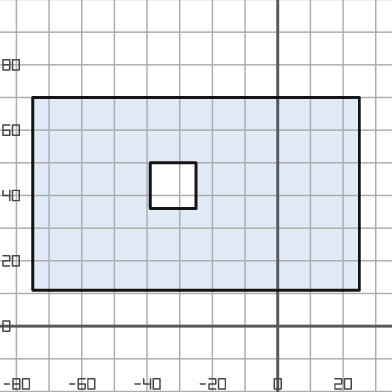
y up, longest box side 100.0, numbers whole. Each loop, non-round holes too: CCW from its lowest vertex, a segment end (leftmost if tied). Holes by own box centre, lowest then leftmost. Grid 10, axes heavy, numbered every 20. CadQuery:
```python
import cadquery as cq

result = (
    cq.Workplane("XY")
    .moveTo(-75.0, 11.0)
    .lineTo(25.0, 11.0)
    .lineTo(25.0, 70.0)
    .lineTo(-75.0, 70.0)
    .close()
    .moveTo(-39.0, 36.0)
    .lineTo(-25.0, 36.0)
    .lineTo(-25.0, 50.0)
    .lineTo(-39.0, 50.0)
    .close()
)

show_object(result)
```